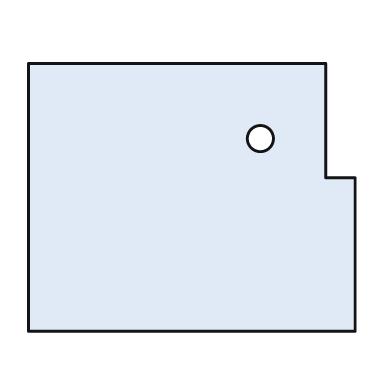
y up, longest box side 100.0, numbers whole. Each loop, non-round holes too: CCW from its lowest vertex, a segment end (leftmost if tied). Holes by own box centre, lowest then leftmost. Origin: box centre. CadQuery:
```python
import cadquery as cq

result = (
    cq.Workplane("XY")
    .moveTo(-50.0, -41.0)
    .lineTo(50.0, -41.0)
    .lineTo(50.0, 6.0)
    .lineTo(41.0, 6.0)
    .lineTo(41.0, 41.0)
    .lineTo(-50.0, 41.0)
    .close()
    .moveTo(21.0, 18.0)
    .circle(4.0)
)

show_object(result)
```